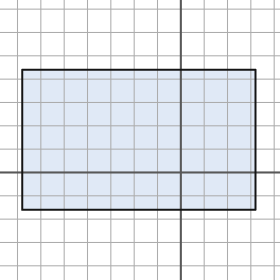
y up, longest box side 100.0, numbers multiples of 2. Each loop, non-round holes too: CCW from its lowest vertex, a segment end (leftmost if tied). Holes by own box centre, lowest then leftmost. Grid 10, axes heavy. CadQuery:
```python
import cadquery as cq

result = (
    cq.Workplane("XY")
    .moveTo(-68.0, -16.0)
    .lineTo(32.0, -16.0)
    .lineTo(32.0, 44.0)
    .lineTo(-68.0, 44.0)
    .close()
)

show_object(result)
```